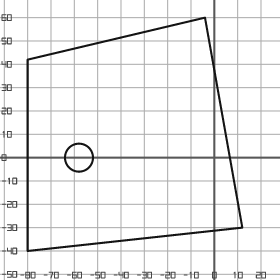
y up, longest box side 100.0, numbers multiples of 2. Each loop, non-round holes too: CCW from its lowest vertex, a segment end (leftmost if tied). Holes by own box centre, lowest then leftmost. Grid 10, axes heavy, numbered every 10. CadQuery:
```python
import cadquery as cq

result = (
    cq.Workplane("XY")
    .moveTo(-80.0, -40.0)
    .lineTo(12.0, -30.0)
    .lineTo(-4.0, 60.0)
    .lineTo(-80.0, 42.0)
    .close()
    .moveTo(-58.0, 0.0)
    .circle(6.0)
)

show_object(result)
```